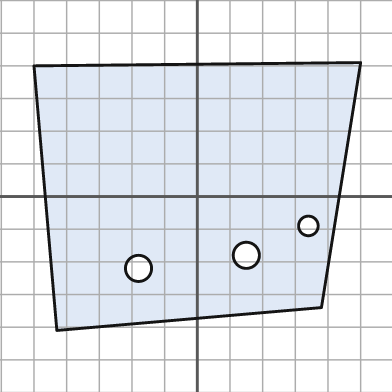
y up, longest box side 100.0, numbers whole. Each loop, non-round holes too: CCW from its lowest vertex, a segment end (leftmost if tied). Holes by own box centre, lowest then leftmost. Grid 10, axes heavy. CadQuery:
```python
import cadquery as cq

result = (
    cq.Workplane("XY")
    .moveTo(-43.0, -41.0)
    .lineTo(38.0, -34.0)
    .lineTo(50.0, 41.0)
    .lineTo(-50.0, 40.0)
    .close()
    .moveTo(-18.0, -22.0)
    .circle(4.0)
    .moveTo(15.0, -18.0)
    .circle(4.0)
    .moveTo(34.0, -9.0)
    .circle(3.0)
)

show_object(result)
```